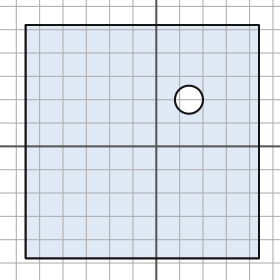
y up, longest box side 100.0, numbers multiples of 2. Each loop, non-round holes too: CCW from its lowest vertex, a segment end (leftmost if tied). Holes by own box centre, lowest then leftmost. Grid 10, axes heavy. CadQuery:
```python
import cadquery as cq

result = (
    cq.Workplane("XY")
    .moveTo(-56.0, -48.0)
    .lineTo(44.0, -48.0)
    .lineTo(44.0, 52.0)
    .lineTo(-56.0, 52.0)
    .close()
    .moveTo(14.0, 20.0)
    .circle(6.0)
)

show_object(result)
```